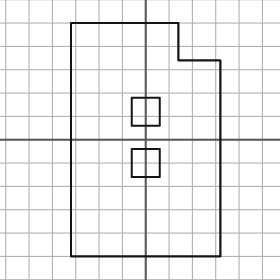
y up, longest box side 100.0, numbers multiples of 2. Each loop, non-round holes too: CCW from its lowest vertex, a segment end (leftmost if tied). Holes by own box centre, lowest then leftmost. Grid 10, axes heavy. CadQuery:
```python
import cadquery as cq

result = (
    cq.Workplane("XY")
    .moveTo(-32.0, -50.0)
    .lineTo(32.0, -50.0)
    .lineTo(32.0, 34.0)
    .lineTo(14.0, 34.0)
    .lineTo(14.0, 50.0)
    .lineTo(-32.0, 50.0)
    .close()
    .moveTo(-6.0, -16.0)
    .lineTo(6.0, -16.0)
    .lineTo(6.0, -4.0)
    .lineTo(-6.0, -4.0)
    .close()
    .moveTo(-6.0, 6.0)
    .lineTo(6.0, 6.0)
    .lineTo(6.0, 18.0)
    .lineTo(-6.0, 18.0)
    .close()
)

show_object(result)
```